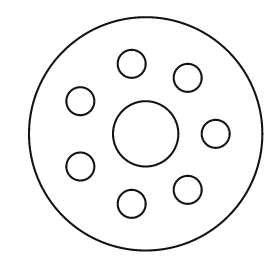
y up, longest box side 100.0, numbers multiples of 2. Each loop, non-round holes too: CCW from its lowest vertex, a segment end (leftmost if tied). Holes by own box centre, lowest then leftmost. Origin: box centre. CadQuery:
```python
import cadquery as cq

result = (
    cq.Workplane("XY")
    .moveTo(0.0, 0.0)
    .circle(50.0)
    .moveTo(-6.0, -30.0)
    .circle(6.0)
    .moveTo(18.0, -24.0)
    .circle(6.0)
    .moveTo(-28.0, -14.0)
    .circle(6.0)
    .moveTo(0.0, 0.0)
    .circle(14.0)
    .moveTo(30.0, 0.0)
    .circle(6.0)
    .moveTo(-28.0, 14.0)
    .circle(6.0)
    .moveTo(18.0, 24.0)
    .circle(6.0)
    .moveTo(-6.0, 30.0)
    .circle(6.0)
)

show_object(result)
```